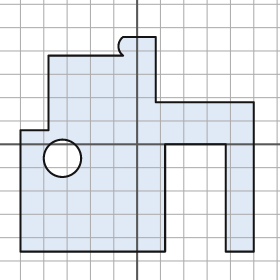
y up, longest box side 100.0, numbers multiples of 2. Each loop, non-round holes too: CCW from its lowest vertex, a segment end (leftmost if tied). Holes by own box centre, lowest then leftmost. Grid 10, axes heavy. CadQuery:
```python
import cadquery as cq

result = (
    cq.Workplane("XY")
    .moveTo(-50.0, -46.0)
    .lineTo(12.0, -46.0)
    .lineTo(12.0, 0.0)
    .lineTo(38.0, 0.0)
    .lineTo(38.0, -46.0)
    .lineTo(50.0, -46.0)
    .lineTo(50.0, 18.0)
    .lineTo(8.0, 18.0)
    .lineTo(8.0, 46.0)
    .lineTo(-6.0, 46.0)
    .threePointArc((-8.0, 42.0), (-6.0, 38.0))
    .lineTo(-38.0, 38.0)
    .lineTo(-38.0, 6.0)
    .lineTo(-50.0, 6.0)
    .close()
    .moveTo(-32.0, -6.0)
    .circle(8.0)
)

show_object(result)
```